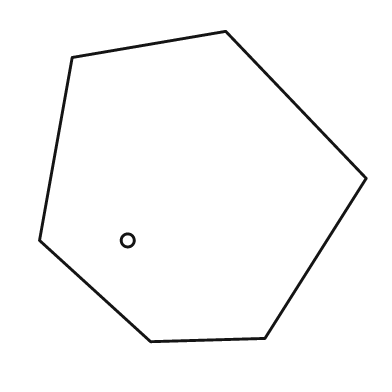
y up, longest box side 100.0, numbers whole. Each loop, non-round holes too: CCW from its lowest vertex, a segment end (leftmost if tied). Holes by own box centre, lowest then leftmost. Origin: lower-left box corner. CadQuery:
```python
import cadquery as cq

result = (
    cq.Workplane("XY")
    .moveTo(34.0, 0.0)
    .lineTo(69.0, 1.0)
    .lineTo(100.0, 50.0)
    .lineTo(57.0, 95.0)
    .lineTo(10.0, 87.0)
    .lineTo(0.0, 31.0)
    .close()
    .moveTo(27.0, 31.0)
    .circle(2.0)
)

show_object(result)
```